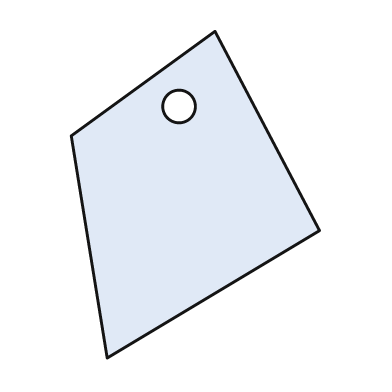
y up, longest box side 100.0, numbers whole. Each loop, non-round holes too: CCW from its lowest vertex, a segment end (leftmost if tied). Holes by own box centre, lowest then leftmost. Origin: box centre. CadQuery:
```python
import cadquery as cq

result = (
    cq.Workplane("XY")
    .moveTo(-27.0, -50.0)
    .lineTo(38.0, -11.0)
    .lineTo(6.0, 50.0)
    .lineTo(-38.0, 18.0)
    .close()
    .moveTo(-5.0, 27.0)
    .circle(5.0)
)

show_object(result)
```